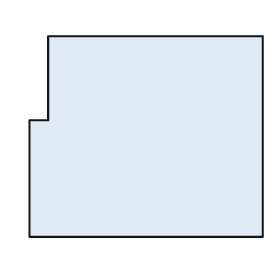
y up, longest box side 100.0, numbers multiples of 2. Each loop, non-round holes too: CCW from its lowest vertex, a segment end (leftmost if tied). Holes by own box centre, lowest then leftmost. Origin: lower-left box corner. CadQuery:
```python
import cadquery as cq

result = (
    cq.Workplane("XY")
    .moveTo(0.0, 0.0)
    .lineTo(100.0, 0.0)
    .lineTo(100.0, 86.0)
    .lineTo(8.0, 86.0)
    .lineTo(8.0, 50.0)
    .lineTo(0.0, 50.0)
    .close()
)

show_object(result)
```